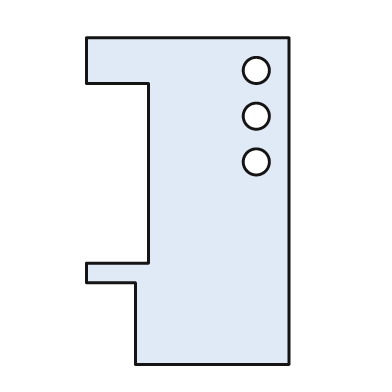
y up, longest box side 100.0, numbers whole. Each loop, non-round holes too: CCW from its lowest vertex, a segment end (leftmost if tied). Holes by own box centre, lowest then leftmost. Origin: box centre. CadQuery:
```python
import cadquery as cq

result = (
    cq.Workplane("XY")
    .moveTo(-16.0, -50.0)
    .lineTo(31.0, -50.0)
    .lineTo(31.0, 50.0)
    .lineTo(-31.0, 50.0)
    .lineTo(-31.0, 36.0)
    .lineTo(-12.0, 36.0)
    .lineTo(-12.0, -19.0)
    .lineTo(-31.0, -19.0)
    .lineTo(-31.0, -25.0)
    .lineTo(-16.0, -25.0)
    .close()
    .moveTo(21.0, 12.0)
    .circle(4.0)
    .moveTo(21.0, 26.0)
    .circle(4.0)
    .moveTo(21.0, 40.0)
    .circle(4.0)
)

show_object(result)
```